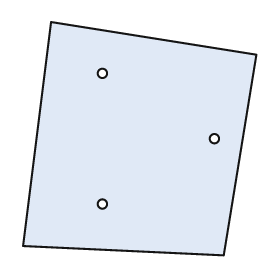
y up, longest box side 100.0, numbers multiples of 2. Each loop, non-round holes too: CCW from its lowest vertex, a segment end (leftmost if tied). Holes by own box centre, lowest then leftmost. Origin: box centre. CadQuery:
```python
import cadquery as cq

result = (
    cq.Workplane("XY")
    .moveTo(36.0, -50.0)
    .lineTo(50.0, 36.0)
    .lineTo(-38.0, 50.0)
    .lineTo(-50.0, -46.0)
    .close()
    .moveTo(-16.0, -28.0)
    .circle(2.0)
    .moveTo(32.0, 0.0)
    .circle(2.0)
    .moveTo(-16.0, 28.0)
    .circle(2.0)
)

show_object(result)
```